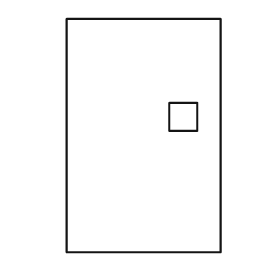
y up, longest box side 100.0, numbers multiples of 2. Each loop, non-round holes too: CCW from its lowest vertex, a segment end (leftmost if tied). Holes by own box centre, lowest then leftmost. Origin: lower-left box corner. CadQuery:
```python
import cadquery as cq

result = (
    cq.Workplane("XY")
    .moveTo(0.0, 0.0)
    .lineTo(66.0, 0.0)
    .lineTo(66.0, 100.0)
    .lineTo(0.0, 100.0)
    .close()
    .moveTo(44.0, 52.0)
    .lineTo(56.0, 52.0)
    .lineTo(56.0, 64.0)
    .lineTo(44.0, 64.0)
    .close()
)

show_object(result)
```